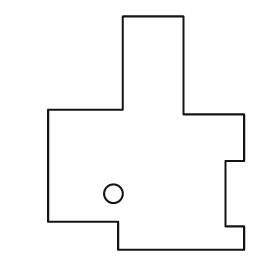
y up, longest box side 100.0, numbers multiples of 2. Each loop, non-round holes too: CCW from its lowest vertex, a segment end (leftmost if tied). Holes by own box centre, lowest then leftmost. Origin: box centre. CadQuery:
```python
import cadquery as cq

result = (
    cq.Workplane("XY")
    .moveTo(-12.0, -50.0)
    .lineTo(42.0, -50.0)
    .lineTo(42.0, -40.0)
    .lineTo(34.0, -40.0)
    .lineTo(34.0, -12.0)
    .lineTo(42.0, -12.0)
    .lineTo(42.0, 8.0)
    .lineTo(16.0, 8.0)
    .lineTo(16.0, 50.0)
    .lineTo(-10.0, 50.0)
    .lineTo(-10.0, 10.0)
    .lineTo(-42.0, 10.0)
    .lineTo(-42.0, -38.0)
    .lineTo(-12.0, -38.0)
    .close()
    .moveTo(-14.0, -26.0)
    .circle(4.0)
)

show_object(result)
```